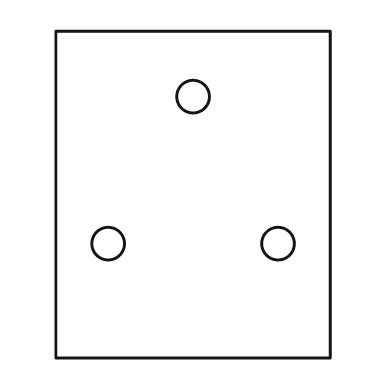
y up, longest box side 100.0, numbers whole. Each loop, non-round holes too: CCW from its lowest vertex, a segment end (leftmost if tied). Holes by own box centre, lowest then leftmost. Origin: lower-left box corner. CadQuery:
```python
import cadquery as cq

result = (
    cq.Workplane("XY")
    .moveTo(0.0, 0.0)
    .lineTo(84.0, 0.0)
    .lineTo(84.0, 100.0)
    .lineTo(0.0, 100.0)
    .close()
    .moveTo(16.0, 35.0)
    .circle(5.0)
    .moveTo(68.0, 35.0)
    .circle(5.0)
    .moveTo(42.0, 80.0)
    .circle(5.0)
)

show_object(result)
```